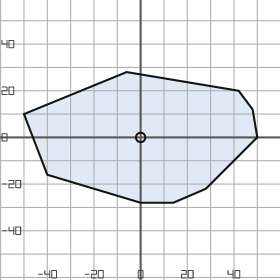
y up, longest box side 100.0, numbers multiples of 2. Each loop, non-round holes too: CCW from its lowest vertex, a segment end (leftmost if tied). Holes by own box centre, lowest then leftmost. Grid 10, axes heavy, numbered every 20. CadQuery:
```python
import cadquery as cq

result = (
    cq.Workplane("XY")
    .moveTo(0.0, -28.0)
    .lineTo(14.0, -28.0)
    .lineTo(28.0, -22.0)
    .lineTo(50.0, 0.0)
    .lineTo(48.0, 12.0)
    .lineTo(42.0, 20.0)
    .lineTo(-6.0, 28.0)
    .lineTo(-50.0, 10.0)
    .lineTo(-40.0, -16.0)
    .close()
    .moveTo(0.0, 0.0)
    .circle(2.0)
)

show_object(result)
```